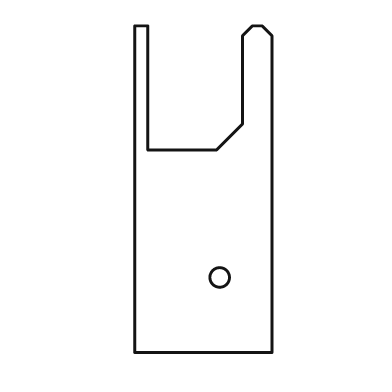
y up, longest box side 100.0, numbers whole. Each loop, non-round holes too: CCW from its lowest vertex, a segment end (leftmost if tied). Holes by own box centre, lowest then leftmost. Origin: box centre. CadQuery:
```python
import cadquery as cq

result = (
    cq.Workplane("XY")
    .moveTo(-21.0, -50.0)
    .lineTo(21.0, -50.0)
    .lineTo(21.0, 47.0)
    .lineTo(18.0, 50.0)
    .lineTo(15.0, 50.0)
    .lineTo(12.0, 47.0)
    .lineTo(12.0, 20.0)
    .lineTo(4.0, 12.0)
    .lineTo(-17.0, 12.0)
    .lineTo(-17.0, 50.0)
    .lineTo(-21.0, 50.0)
    .close()
    .moveTo(5.0, -27.0)
    .circle(3.0)
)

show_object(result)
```